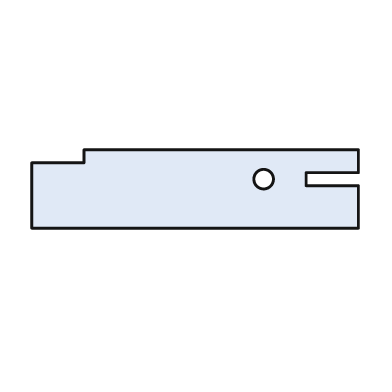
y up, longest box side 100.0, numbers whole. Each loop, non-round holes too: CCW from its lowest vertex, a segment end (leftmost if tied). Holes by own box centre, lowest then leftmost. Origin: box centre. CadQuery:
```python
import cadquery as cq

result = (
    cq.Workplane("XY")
    .moveTo(-50.0, -12.0)
    .lineTo(50.0, -12.0)
    .lineTo(50.0, 1.0)
    .lineTo(34.0, 1.0)
    .lineTo(34.0, 5.0)
    .lineTo(50.0, 5.0)
    .lineTo(50.0, 12.0)
    .lineTo(-34.0, 12.0)
    .lineTo(-34.0, 8.0)
    .lineTo(-50.0, 8.0)
    .close()
    .moveTo(21.0, 3.0)
    .circle(3.0)
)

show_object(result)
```